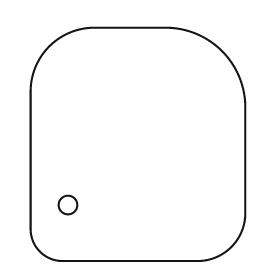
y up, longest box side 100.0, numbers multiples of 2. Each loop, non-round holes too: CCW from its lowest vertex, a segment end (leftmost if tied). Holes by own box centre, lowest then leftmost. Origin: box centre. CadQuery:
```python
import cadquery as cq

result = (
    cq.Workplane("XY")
    .moveTo(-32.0, -50.0)
    .lineTo(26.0, -50.0)
    .threePointArc((40.0, -44.0), (46.0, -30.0))
    .lineTo(46.0, 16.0)
    .threePointArc((36.0, 40.0), (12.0, 50.0))
    .lineTo(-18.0, 50.0)
    .threePointArc((-38.0, 42.0), (-46.0, 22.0))
    .lineTo(-46.0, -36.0)
    .threePointArc((-42.0, -46.0), (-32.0, -50.0))
    .close()
    .moveTo(-30.0, -26.0)
    .circle(4.0)
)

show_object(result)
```